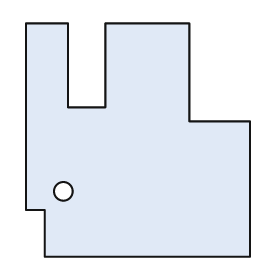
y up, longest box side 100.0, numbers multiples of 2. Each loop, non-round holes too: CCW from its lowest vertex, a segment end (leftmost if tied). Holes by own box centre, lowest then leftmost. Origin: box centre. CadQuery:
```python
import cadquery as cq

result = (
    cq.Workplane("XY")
    .moveTo(-40.0, -50.0)
    .lineTo(48.0, -50.0)
    .lineTo(48.0, 8.0)
    .lineTo(22.0, 8.0)
    .lineTo(22.0, 50.0)
    .lineTo(-14.0, 50.0)
    .lineTo(-14.0, 14.0)
    .lineTo(-30.0, 14.0)
    .lineTo(-30.0, 50.0)
    .lineTo(-48.0, 50.0)
    .lineTo(-48.0, -30.0)
    .lineTo(-40.0, -30.0)
    .close()
    .moveTo(-32.0, -22.0)
    .circle(4.0)
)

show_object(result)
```